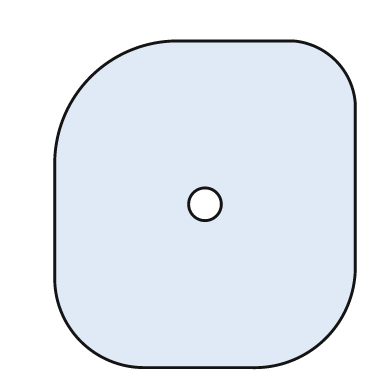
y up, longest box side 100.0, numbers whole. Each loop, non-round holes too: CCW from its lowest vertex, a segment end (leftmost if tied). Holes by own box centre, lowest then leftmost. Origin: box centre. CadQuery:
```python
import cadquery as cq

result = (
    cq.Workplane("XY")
    .moveTo(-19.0, -50.0)
    .lineTo(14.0, -50.0)
    .threePointArc((37.0, -41.0), (46.0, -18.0))
    .lineTo(46.0, 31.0)
    .threePointArc((40.0, 44.0), (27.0, 50.0))
    .lineTo(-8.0, 50.0)
    .threePointArc((-35.0, 39.0), (-46.0, 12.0))
    .lineTo(-46.0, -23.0)
    .threePointArc((-38.0, -42.0), (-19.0, -50.0))
    .close()
    .moveTo(0.0, 0.0)
    .circle(5.0)
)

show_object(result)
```